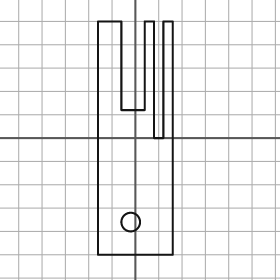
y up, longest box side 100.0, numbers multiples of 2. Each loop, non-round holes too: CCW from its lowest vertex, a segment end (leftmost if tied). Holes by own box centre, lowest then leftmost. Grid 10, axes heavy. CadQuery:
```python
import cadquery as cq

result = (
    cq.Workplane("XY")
    .moveTo(-16.0, -50.0)
    .lineTo(16.0, -50.0)
    .lineTo(16.0, 50.0)
    .lineTo(12.0, 50.0)
    .lineTo(12.0, 0.0)
    .lineTo(8.0, 0.0)
    .lineTo(8.0, 50.0)
    .lineTo(4.0, 50.0)
    .lineTo(4.0, 12.0)
    .lineTo(-6.0, 12.0)
    .lineTo(-6.0, 50.0)
    .lineTo(-16.0, 50.0)
    .close()
    .moveTo(-2.0, -36.0)
    .circle(4.0)
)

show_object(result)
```